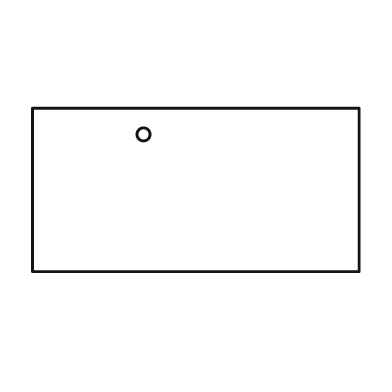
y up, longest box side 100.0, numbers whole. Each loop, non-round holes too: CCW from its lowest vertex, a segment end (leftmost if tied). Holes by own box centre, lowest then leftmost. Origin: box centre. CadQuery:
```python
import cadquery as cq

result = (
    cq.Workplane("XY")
    .moveTo(-50.0, -25.0)
    .lineTo(50.0, -25.0)
    .lineTo(50.0, 25.0)
    .lineTo(-50.0, 25.0)
    .close()
    .moveTo(-16.0, 17.0)
    .circle(2.0)
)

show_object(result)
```